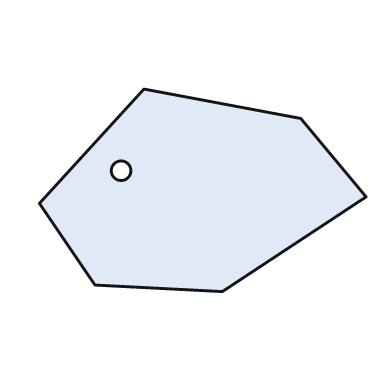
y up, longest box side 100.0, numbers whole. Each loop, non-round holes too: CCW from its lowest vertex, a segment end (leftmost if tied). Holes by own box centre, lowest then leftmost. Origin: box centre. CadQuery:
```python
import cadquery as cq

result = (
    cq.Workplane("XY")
    .moveTo(6.0, -31.0)
    .lineTo(50.0, -2.0)
    .lineTo(30.0, 22.0)
    .lineTo(-18.0, 31.0)
    .lineTo(-50.0, -4.0)
    .lineTo(-33.0, -29.0)
    .close()
    .moveTo(-25.0, 6.0)
    .circle(3.0)
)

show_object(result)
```